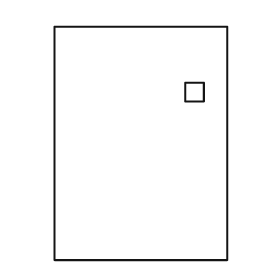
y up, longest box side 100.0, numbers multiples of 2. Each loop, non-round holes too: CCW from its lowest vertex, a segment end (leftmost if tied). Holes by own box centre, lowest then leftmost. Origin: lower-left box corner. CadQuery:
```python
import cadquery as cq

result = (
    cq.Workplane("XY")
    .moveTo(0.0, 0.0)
    .lineTo(74.0, 0.0)
    .lineTo(74.0, 100.0)
    .lineTo(0.0, 100.0)
    .close()
    .moveTo(56.0, 68.0)
    .lineTo(64.0, 68.0)
    .lineTo(64.0, 76.0)
    .lineTo(56.0, 76.0)
    .close()
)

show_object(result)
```